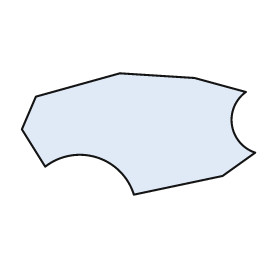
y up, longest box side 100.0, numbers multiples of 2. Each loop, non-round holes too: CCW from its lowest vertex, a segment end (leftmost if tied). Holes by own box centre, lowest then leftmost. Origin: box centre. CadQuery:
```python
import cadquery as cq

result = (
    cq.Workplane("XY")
    .moveTo(-2.0, -26.0)
    .lineTo(36.0, -18.0)
    .lineTo(50.0, -8.0)
    .threePointArc((40.0, 4.0), (46.0, 18.0))
    .lineTo(24.0, 24.0)
    .lineTo(-8.0, 26.0)
    .lineTo(-44.0, 16.0)
    .lineTo(-50.0, 2.0)
    .lineTo(-40.0, -14.0)
    .threePointArc((-18.0, -10.0), (-2.0, -26.0))
    .close()
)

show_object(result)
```